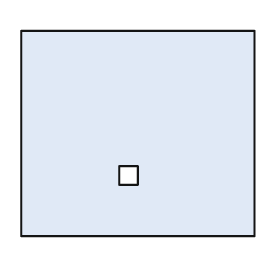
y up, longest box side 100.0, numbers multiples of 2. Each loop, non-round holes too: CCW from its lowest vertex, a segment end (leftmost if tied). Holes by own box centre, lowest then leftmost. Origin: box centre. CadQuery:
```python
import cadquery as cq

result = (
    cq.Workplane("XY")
    .moveTo(-50.0, -44.0)
    .lineTo(50.0, -44.0)
    .lineTo(50.0, 44.0)
    .lineTo(-50.0, 44.0)
    .close()
    .moveTo(-8.0, -22.0)
    .lineTo(0.0, -22.0)
    .lineTo(0.0, -14.0)
    .lineTo(-8.0, -14.0)
    .close()
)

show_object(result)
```